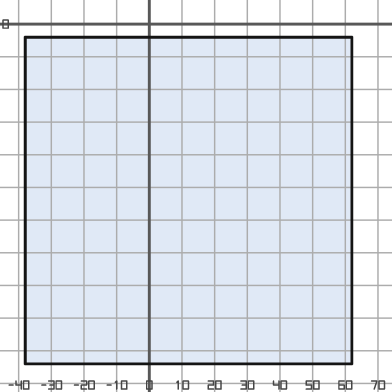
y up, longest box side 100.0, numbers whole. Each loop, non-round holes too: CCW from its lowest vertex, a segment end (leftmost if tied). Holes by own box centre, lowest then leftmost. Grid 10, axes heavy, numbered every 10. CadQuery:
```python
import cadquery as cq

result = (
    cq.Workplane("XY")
    .moveTo(-38.0, -104.0)
    .lineTo(62.0, -104.0)
    .lineTo(62.0, -4.0)
    .lineTo(-38.0, -4.0)
    .close()
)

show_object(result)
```